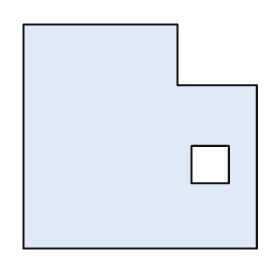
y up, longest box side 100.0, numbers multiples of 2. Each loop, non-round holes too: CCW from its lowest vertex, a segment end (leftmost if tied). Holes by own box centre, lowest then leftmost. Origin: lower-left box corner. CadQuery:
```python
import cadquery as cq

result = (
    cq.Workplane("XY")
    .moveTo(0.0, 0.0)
    .lineTo(100.0, 0.0)
    .lineTo(100.0, 70.0)
    .lineTo(66.0, 70.0)
    .lineTo(66.0, 96.0)
    .lineTo(0.0, 96.0)
    .close()
    .moveTo(72.0, 28.0)
    .lineTo(88.0, 28.0)
    .lineTo(88.0, 44.0)
    .lineTo(72.0, 44.0)
    .close()
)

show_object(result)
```